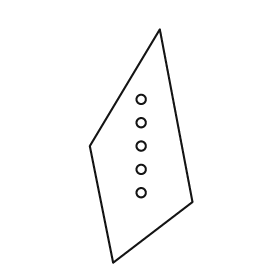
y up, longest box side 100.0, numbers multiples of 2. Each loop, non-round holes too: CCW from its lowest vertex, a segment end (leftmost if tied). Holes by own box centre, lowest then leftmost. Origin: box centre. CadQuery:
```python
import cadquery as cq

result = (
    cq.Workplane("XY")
    .moveTo(-12.0, -50.0)
    .lineTo(22.0, -24.0)
    .lineTo(8.0, 50.0)
    .lineTo(-22.0, 0.0)
    .close()
    .moveTo(0.0, -20.0)
    .circle(2.0)
    .moveTo(0.0, -10.0)
    .circle(2.0)
    .moveTo(0.0, 0.0)
    .circle(2.0)
    .moveTo(0.0, 10.0)
    .circle(2.0)
    .moveTo(0.0, 20.0)
    .circle(2.0)
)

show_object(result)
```